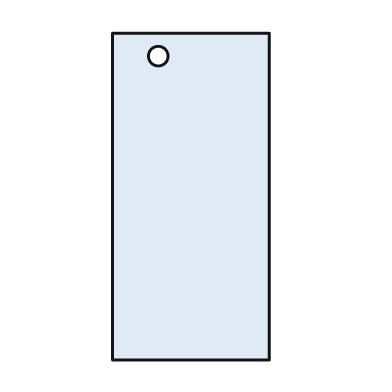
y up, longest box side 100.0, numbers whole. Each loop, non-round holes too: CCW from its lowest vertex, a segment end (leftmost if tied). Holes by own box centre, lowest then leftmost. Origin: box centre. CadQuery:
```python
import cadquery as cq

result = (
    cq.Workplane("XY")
    .moveTo(-24.0, -50.0)
    .lineTo(24.0, -50.0)
    .lineTo(24.0, 50.0)
    .lineTo(-24.0, 50.0)
    .close()
    .moveTo(-10.0, 43.0)
    .circle(3.0)
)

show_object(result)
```